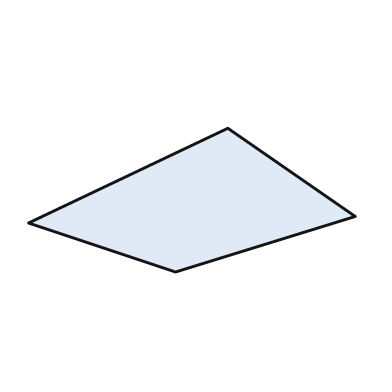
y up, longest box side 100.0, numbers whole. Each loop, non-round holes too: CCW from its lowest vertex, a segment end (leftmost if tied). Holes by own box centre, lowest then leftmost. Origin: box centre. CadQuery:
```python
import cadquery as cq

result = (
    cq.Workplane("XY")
    .moveTo(-5.0, -22.0)
    .lineTo(50.0, -5.0)
    .lineTo(11.0, 22.0)
    .lineTo(-50.0, -7.0)
    .close()
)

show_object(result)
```